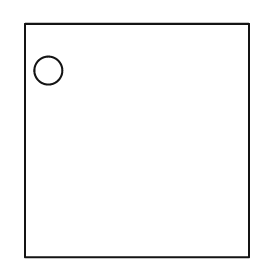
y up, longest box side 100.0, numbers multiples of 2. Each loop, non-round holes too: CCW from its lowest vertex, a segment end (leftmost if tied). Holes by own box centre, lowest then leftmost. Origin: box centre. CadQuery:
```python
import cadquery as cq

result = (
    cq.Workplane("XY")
    .moveTo(-48.0, -50.0)
    .lineTo(48.0, -50.0)
    .lineTo(48.0, 50.0)
    .lineTo(-48.0, 50.0)
    .close()
    .moveTo(-38.0, 30.0)
    .circle(6.0)
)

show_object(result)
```